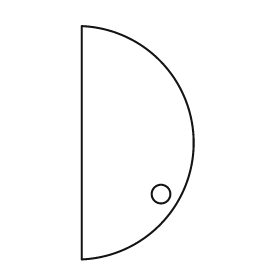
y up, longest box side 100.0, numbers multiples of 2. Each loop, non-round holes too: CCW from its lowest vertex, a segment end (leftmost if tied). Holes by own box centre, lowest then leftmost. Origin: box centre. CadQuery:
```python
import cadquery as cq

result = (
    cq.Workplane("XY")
    .moveTo(-24.0, -50.0)
    .threePointArc((24.0, 0.0), (-24.0, 50.0))
    .close()
    .moveTo(10.0, -22.0)
    .circle(4.0)
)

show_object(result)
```